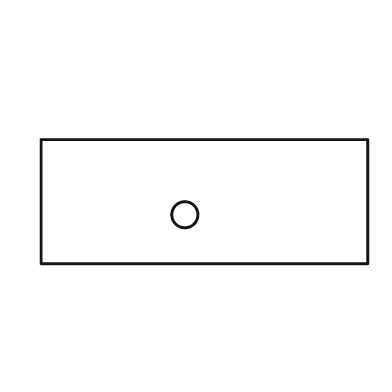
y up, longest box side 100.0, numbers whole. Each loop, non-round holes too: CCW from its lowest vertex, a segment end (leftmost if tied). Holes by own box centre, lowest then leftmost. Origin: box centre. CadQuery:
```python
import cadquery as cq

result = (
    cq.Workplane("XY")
    .moveTo(-50.0, -19.0)
    .lineTo(50.0, -19.0)
    .lineTo(50.0, 19.0)
    .lineTo(-50.0, 19.0)
    .close()
    .moveTo(-6.0, -4.0)
    .circle(4.0)
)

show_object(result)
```